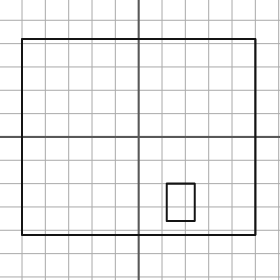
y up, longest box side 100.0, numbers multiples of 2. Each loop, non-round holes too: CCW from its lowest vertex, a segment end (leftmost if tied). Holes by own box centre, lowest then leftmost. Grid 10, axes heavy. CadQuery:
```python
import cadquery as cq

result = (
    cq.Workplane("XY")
    .moveTo(-50.0, -42.0)
    .lineTo(50.0, -42.0)
    .lineTo(50.0, 42.0)
    .lineTo(-50.0, 42.0)
    .close()
    .moveTo(12.0, -36.0)
    .lineTo(24.0, -36.0)
    .lineTo(24.0, -20.0)
    .lineTo(12.0, -20.0)
    .close()
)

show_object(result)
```